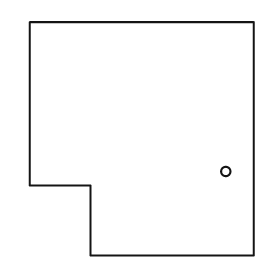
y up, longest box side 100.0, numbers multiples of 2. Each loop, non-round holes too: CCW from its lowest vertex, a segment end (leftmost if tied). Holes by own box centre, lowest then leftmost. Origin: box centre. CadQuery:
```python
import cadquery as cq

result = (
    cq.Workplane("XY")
    .moveTo(-22.0, -50.0)
    .lineTo(48.0, -50.0)
    .lineTo(48.0, 50.0)
    .lineTo(-48.0, 50.0)
    .lineTo(-48.0, -20.0)
    .lineTo(-22.0, -20.0)
    .close()
    .moveTo(36.0, -14.0)
    .circle(2.0)
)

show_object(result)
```